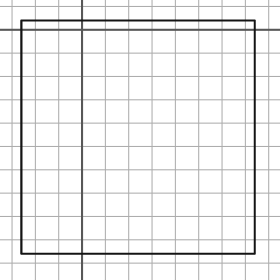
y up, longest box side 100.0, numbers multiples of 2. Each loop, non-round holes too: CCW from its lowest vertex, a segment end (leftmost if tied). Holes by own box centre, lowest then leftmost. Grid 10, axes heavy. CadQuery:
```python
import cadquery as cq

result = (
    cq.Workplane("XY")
    .moveTo(-26.0, -96.0)
    .lineTo(74.0, -96.0)
    .lineTo(74.0, 4.0)
    .lineTo(-26.0, 4.0)
    .close()
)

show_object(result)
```